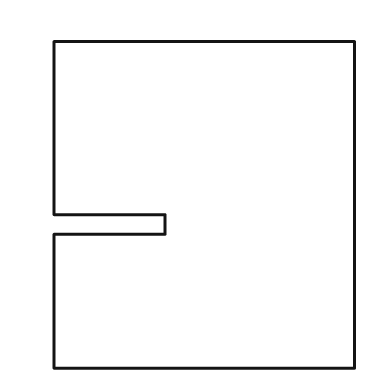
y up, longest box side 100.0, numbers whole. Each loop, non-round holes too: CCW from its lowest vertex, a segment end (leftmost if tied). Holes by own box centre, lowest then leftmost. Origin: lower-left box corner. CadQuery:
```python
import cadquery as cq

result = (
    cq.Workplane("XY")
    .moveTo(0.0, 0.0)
    .lineTo(92.0, 0.0)
    .lineTo(92.0, 100.0)
    .lineTo(0.0, 100.0)
    .lineTo(0.0, 47.0)
    .lineTo(34.0, 47.0)
    .lineTo(34.0, 41.0)
    .lineTo(0.0, 41.0)
    .close()
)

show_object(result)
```